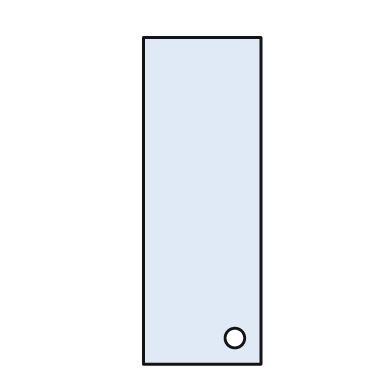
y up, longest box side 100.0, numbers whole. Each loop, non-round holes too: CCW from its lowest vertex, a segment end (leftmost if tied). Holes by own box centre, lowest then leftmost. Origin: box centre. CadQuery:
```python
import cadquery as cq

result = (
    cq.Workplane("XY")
    .moveTo(-18.0, -50.0)
    .lineTo(18.0, -50.0)
    .lineTo(18.0, 50.0)
    .lineTo(-18.0, 50.0)
    .close()
    .moveTo(10.0, -42.0)
    .circle(3.0)
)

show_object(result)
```